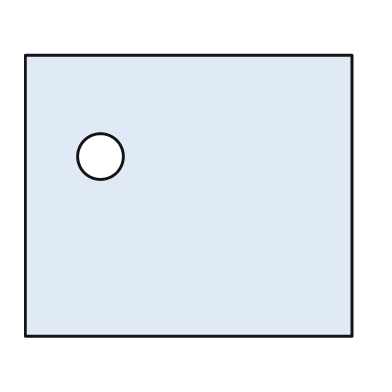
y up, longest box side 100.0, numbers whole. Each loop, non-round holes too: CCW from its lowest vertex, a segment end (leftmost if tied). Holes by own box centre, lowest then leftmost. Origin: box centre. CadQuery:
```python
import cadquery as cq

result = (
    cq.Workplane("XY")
    .moveTo(-50.0, -43.0)
    .lineTo(50.0, -43.0)
    .lineTo(50.0, 43.0)
    .lineTo(-50.0, 43.0)
    .close()
    .moveTo(-27.0, 12.0)
    .circle(7.0)
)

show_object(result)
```